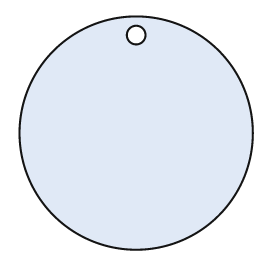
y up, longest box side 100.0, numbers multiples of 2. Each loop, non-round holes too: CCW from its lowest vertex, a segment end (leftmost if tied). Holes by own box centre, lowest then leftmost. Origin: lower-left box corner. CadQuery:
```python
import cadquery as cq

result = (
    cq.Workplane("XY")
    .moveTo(50.0, 50.0)
    .circle(50.0)
    .moveTo(50.0, 92.0)
    .circle(4.0)
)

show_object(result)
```